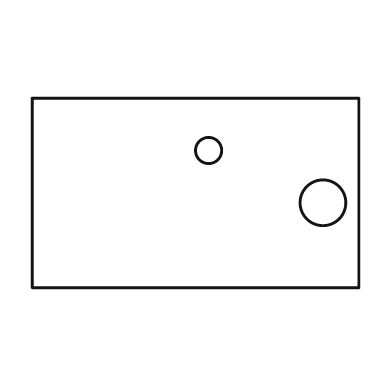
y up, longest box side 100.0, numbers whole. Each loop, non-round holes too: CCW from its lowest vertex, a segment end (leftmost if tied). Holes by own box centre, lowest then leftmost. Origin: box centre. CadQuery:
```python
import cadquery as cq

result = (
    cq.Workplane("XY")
    .moveTo(-50.0, -29.0)
    .lineTo(50.0, -29.0)
    .lineTo(50.0, 29.0)
    .lineTo(-50.0, 29.0)
    .close()
    .moveTo(39.0, -3.0)
    .circle(7.0)
    .moveTo(4.0, 13.0)
    .circle(4.0)
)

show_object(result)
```